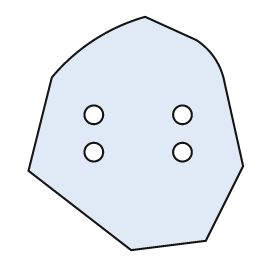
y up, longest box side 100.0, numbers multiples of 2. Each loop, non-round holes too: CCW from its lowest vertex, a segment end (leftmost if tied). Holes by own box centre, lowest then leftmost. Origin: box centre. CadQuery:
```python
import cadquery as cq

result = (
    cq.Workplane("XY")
    .moveTo(-2.0, -50.0)
    .lineTo(30.0, -46.0)
    .lineTo(46.0, -14.0)
    .lineTo(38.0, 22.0)
    .threePointArc((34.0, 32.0), (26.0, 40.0))
    .lineTo(4.0, 50.0)
    .threePointArc((-18.0, 40.0), (-36.0, 24.0))
    .lineTo(-46.0, -16.0)
    .close()
    .moveTo(-18.0, -8.0)
    .circle(4.0)
    .moveTo(20.0, -8.0)
    .circle(4.0)
    .moveTo(-18.0, 8.0)
    .circle(4.0)
    .moveTo(20.0, 8.0)
    .circle(4.0)
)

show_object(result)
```